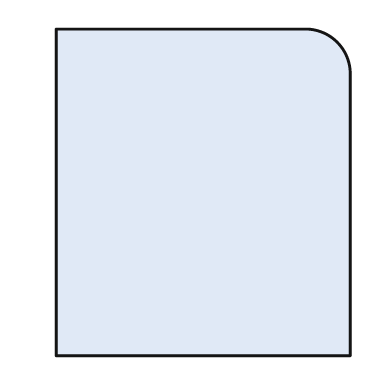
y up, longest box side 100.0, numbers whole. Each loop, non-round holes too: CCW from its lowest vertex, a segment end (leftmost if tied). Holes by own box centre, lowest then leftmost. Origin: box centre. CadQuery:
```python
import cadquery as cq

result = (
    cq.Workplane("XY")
    .moveTo(-45.0, -50.0)
    .lineTo(45.0, -50.0)
    .lineTo(45.0, 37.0)
    .threePointArc((41.0, 46.0), (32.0, 50.0))
    .lineTo(-45.0, 50.0)
    .close()
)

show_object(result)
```